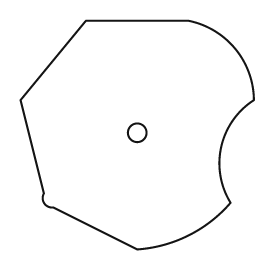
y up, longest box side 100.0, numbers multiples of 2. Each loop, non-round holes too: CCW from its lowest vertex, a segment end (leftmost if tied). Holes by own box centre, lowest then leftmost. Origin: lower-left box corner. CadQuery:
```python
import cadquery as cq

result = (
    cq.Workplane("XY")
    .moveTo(50.0, 0.0)
    .threePointArc((72.0, 6.0), (90.0, 20.0))
    .threePointArc((86.0, 44.0), (100.0, 64.0))
    .threePointArc((92.0, 86.0), (72.0, 98.0))
    .lineTo(28.0, 98.0)
    .lineTo(0.0, 64.0)
    .lineTo(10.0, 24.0)
    .threePointArc((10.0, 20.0), (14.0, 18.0))
    .close()
    .moveTo(50.0, 50.0)
    .circle(4.0)
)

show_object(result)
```